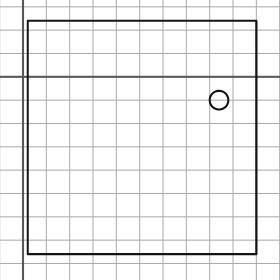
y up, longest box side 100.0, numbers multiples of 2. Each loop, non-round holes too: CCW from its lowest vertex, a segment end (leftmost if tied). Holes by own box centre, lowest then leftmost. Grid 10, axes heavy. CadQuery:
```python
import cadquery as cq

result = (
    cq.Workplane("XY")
    .moveTo(2.0, -76.0)
    .lineTo(100.0, -76.0)
    .lineTo(100.0, 24.0)
    .lineTo(2.0, 24.0)
    .close()
    .moveTo(84.0, -10.0)
    .circle(4.0)
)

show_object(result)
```